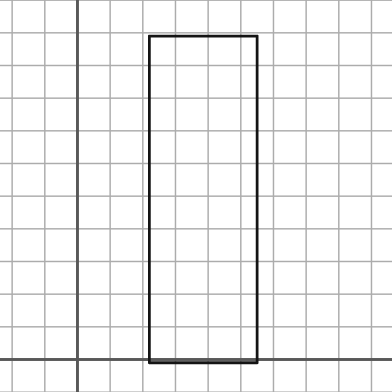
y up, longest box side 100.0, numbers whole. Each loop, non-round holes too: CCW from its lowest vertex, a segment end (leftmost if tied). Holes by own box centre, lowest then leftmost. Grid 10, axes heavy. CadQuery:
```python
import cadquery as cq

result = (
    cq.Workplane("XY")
    .moveTo(22.0, -1.0)
    .lineTo(55.0, -1.0)
    .lineTo(55.0, 99.0)
    .lineTo(22.0, 99.0)
    .close()
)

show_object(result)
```